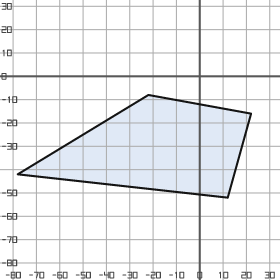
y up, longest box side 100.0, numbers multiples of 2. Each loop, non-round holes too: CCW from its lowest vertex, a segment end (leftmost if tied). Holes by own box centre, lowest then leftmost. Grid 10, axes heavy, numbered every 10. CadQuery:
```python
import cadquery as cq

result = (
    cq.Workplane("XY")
    .moveTo(12.0, -52.0)
    .lineTo(22.0, -16.0)
    .lineTo(-22.0, -8.0)
    .lineTo(-78.0, -42.0)
    .close()
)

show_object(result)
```